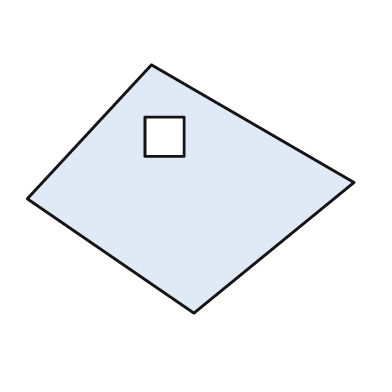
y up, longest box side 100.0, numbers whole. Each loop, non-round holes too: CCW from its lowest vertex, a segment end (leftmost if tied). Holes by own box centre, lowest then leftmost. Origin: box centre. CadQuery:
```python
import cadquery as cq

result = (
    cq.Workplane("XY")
    .moveTo(1.0, -38.0)
    .lineTo(50.0, 2.0)
    .lineTo(-12.0, 38.0)
    .lineTo(-50.0, -3.0)
    .close()
    .moveTo(-14.0, 10.0)
    .lineTo(-2.0, 10.0)
    .lineTo(-2.0, 22.0)
    .lineTo(-14.0, 22.0)
    .close()
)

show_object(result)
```